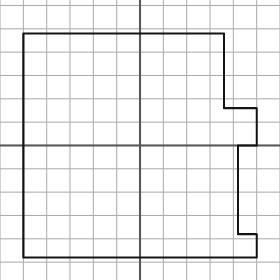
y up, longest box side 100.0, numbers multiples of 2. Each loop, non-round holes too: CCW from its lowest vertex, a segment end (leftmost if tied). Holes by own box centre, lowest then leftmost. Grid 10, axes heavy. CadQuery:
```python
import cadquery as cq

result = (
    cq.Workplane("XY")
    .moveTo(-50.0, -48.0)
    .lineTo(50.0, -48.0)
    .lineTo(50.0, -38.0)
    .lineTo(42.0, -38.0)
    .lineTo(42.0, 0.0)
    .lineTo(50.0, 0.0)
    .lineTo(50.0, 16.0)
    .lineTo(36.0, 16.0)
    .lineTo(36.0, 48.0)
    .lineTo(-50.0, 48.0)
    .close()
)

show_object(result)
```